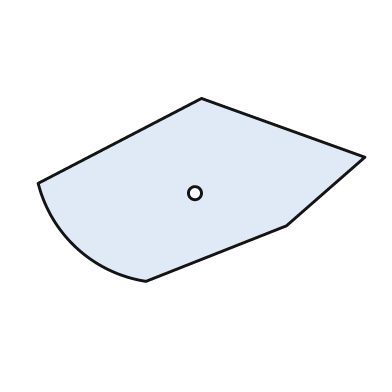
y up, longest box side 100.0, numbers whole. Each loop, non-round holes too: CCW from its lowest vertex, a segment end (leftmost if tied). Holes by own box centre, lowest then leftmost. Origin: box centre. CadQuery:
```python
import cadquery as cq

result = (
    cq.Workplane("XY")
    .moveTo(-17.0, -28.0)
    .lineTo(26.0, -11.0)
    .lineTo(50.0, 10.0)
    .lineTo(0.0, 28.0)
    .lineTo(-50.0, 2.0)
    .threePointArc((-38.0, -18.0), (-17.0, -28.0))
    .close()
    .moveTo(-2.0, -1.0)
    .circle(2.0)
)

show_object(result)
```